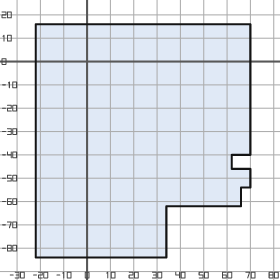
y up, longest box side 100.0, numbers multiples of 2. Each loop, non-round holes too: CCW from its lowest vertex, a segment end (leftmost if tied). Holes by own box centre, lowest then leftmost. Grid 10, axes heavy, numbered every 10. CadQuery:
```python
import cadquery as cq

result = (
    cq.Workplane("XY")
    .moveTo(-22.0, -84.0)
    .lineTo(34.0, -84.0)
    .lineTo(34.0, -62.0)
    .lineTo(66.0, -62.0)
    .lineTo(66.0, -54.0)
    .lineTo(70.0, -54.0)
    .lineTo(70.0, -46.0)
    .lineTo(62.0, -46.0)
    .lineTo(62.0, -40.0)
    .lineTo(70.0, -40.0)
    .lineTo(70.0, 16.0)
    .lineTo(-22.0, 16.0)
    .close()
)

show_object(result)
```